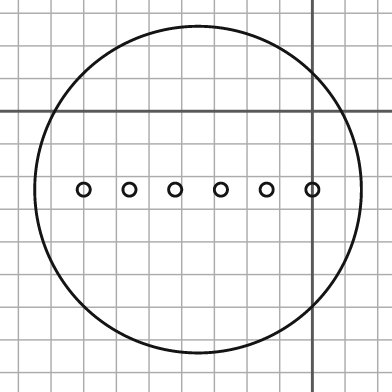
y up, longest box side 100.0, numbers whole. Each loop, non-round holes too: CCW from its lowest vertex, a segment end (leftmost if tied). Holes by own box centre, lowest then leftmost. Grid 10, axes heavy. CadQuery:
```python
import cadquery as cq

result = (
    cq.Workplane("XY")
    .moveTo(-35.0, -24.0)
    .circle(50.0)
    .moveTo(-70.0, -24.0)
    .circle(2.0)
    .moveTo(-56.0, -24.0)
    .circle(2.0)
    .moveTo(-42.0, -24.0)
    .circle(2.0)
    .moveTo(-28.0, -24.0)
    .circle(2.0)
    .moveTo(-14.0, -24.0)
    .circle(2.0)
    .moveTo(0.0, -24.0)
    .circle(2.0)
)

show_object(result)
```